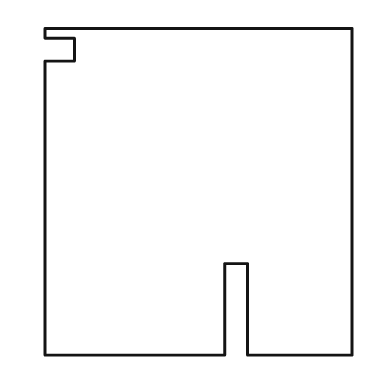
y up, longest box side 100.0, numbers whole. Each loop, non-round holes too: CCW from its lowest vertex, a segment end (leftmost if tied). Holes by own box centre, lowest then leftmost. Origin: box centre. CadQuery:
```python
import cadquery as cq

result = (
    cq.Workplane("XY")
    .moveTo(-47.0, -50.0)
    .lineTo(8.0, -50.0)
    .lineTo(8.0, -22.0)
    .lineTo(15.0, -22.0)
    .lineTo(15.0, -50.0)
    .lineTo(47.0, -50.0)
    .lineTo(47.0, 50.0)
    .lineTo(-47.0, 50.0)
    .lineTo(-47.0, 47.0)
    .lineTo(-38.0, 47.0)
    .lineTo(-38.0, 40.0)
    .lineTo(-47.0, 40.0)
    .close()
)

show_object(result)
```